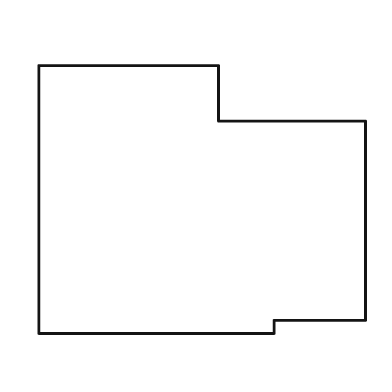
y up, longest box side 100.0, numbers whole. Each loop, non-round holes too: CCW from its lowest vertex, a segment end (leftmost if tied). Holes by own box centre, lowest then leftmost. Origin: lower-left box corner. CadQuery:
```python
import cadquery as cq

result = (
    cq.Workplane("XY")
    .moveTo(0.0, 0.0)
    .lineTo(72.0, 0.0)
    .lineTo(72.0, 4.0)
    .lineTo(100.0, 4.0)
    .lineTo(100.0, 65.0)
    .lineTo(55.0, 65.0)
    .lineTo(55.0, 82.0)
    .lineTo(0.0, 82.0)
    .close()
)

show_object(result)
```